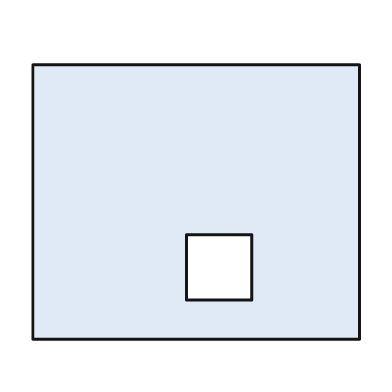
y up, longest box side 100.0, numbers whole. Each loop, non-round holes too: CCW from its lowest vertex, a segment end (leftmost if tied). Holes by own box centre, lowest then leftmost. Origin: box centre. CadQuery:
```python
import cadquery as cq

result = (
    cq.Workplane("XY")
    .moveTo(-50.0, -42.0)
    .lineTo(50.0, -42.0)
    .lineTo(50.0, 42.0)
    .lineTo(-50.0, 42.0)
    .close()
    .moveTo(-3.0, -30.0)
    .lineTo(17.0, -30.0)
    .lineTo(17.0, -10.0)
    .lineTo(-3.0, -10.0)
    .close()
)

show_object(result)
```